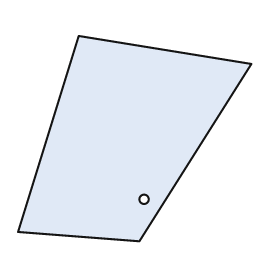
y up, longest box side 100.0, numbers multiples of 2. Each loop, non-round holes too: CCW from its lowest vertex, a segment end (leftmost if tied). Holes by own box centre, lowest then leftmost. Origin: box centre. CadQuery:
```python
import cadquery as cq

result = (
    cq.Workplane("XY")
    .moveTo(2.0, -44.0)
    .lineTo(50.0, 32.0)
    .lineTo(-24.0, 44.0)
    .lineTo(-50.0, -40.0)
    .close()
    .moveTo(4.0, -26.0)
    .circle(2.0)
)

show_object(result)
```